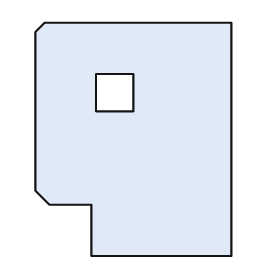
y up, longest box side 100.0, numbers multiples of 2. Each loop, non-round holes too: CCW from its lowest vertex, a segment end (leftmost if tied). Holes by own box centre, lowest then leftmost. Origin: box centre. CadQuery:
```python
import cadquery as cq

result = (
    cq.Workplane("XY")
    .moveTo(-18.0, -50.0)
    .lineTo(42.0, -50.0)
    .lineTo(42.0, 50.0)
    .lineTo(-38.0, 50.0)
    .lineTo(-42.0, 46.0)
    .lineTo(-42.0, -22.0)
    .lineTo(-36.0, -28.0)
    .lineTo(-18.0, -28.0)
    .close()
    .moveTo(-16.0, 12.0)
    .lineTo(0.0, 12.0)
    .lineTo(0.0, 28.0)
    .lineTo(-16.0, 28.0)
    .close()
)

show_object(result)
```